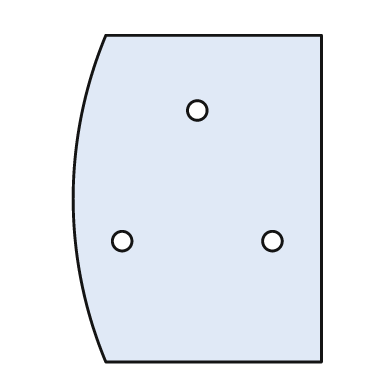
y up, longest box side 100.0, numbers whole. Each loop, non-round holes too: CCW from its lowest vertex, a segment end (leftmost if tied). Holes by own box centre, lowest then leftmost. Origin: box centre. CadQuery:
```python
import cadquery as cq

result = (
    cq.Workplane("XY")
    .moveTo(-28.0, -50.0)
    .lineTo(38.0, -50.0)
    .lineTo(38.0, 50.0)
    .lineTo(-28.0, 50.0)
    .threePointArc((-38.0, 0.0), (-28.0, -50.0))
    .close()
    .moveTo(-23.0, -13.0)
    .circle(3.0)
    .moveTo(23.0, -13.0)
    .circle(3.0)
    .moveTo(0.0, 27.0)
    .circle(3.0)
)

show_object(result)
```